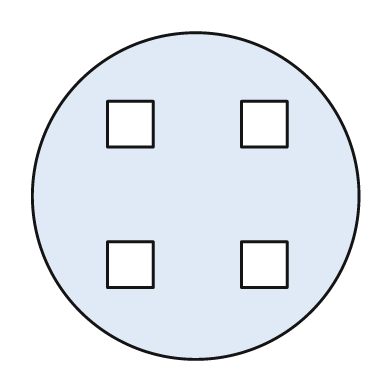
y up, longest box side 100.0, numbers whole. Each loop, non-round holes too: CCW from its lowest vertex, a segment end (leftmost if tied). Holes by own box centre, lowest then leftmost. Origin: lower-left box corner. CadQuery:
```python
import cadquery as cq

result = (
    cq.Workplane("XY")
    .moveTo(50.0, 50.0)
    .circle(50.0)
    .moveTo(23.0, 22.0)
    .lineTo(37.0, 22.0)
    .lineTo(37.0, 36.0)
    .lineTo(23.0, 36.0)
    .close()
    .moveTo(64.0, 22.0)
    .lineTo(78.0, 22.0)
    .lineTo(78.0, 36.0)
    .lineTo(64.0, 36.0)
    .close()
    .moveTo(23.0, 65.0)
    .lineTo(37.0, 65.0)
    .lineTo(37.0, 79.0)
    .lineTo(23.0, 79.0)
    .close()
    .moveTo(64.0, 65.0)
    .lineTo(78.0, 65.0)
    .lineTo(78.0, 79.0)
    .lineTo(64.0, 79.0)
    .close()
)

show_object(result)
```